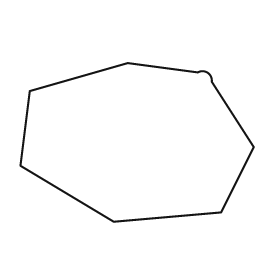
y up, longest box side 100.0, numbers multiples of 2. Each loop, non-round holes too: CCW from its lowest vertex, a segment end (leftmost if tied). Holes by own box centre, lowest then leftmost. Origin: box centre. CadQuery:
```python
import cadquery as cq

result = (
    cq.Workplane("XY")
    .moveTo(-10.0, -34.0)
    .lineTo(36.0, -30.0)
    .lineTo(50.0, -2.0)
    .lineTo(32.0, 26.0)
    .threePointArc((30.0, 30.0), (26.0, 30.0))
    .lineTo(-4.0, 34.0)
    .lineTo(-46.0, 22.0)
    .lineTo(-50.0, -10.0)
    .close()
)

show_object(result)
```